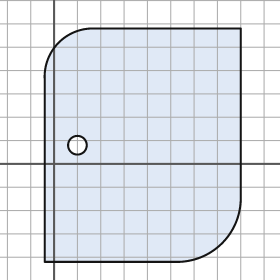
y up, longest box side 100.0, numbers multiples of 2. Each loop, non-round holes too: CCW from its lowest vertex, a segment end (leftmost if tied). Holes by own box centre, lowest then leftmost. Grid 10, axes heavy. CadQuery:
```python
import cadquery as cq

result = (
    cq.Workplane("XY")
    .moveTo(-4.0, -42.0)
    .lineTo(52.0, -42.0)
    .threePointArc((72.0, -34.0), (80.0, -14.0))
    .lineTo(80.0, 58.0)
    .lineTo(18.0, 58.0)
    .threePointArc((2.0, 52.0), (-4.0, 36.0))
    .close()
    .moveTo(10.0, 8.0)
    .circle(4.0)
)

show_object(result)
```